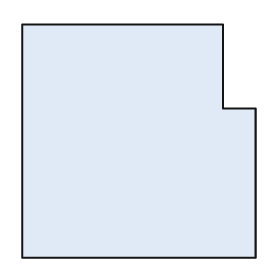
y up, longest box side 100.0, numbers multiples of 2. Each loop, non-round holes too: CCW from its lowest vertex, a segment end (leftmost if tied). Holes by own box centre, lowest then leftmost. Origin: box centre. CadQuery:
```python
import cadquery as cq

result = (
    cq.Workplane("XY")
    .moveTo(-50.0, -50.0)
    .lineTo(50.0, -50.0)
    .lineTo(50.0, 14.0)
    .lineTo(36.0, 14.0)
    .lineTo(36.0, 50.0)
    .lineTo(-50.0, 50.0)
    .close()
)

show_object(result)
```